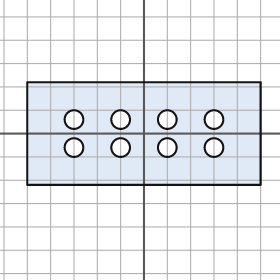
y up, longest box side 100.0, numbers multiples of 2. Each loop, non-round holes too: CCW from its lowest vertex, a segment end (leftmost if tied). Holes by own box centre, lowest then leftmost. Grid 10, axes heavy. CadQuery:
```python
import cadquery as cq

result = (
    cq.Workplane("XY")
    .moveTo(-50.0, -22.0)
    .lineTo(50.0, -22.0)
    .lineTo(50.0, 22.0)
    .lineTo(-50.0, 22.0)
    .close()
    .moveTo(-30.0, -6.0)
    .circle(4.0)
    .moveTo(-10.0, -6.0)
    .circle(4.0)
    .moveTo(10.0, -6.0)
    .circle(4.0)
    .moveTo(30.0, -6.0)
    .circle(4.0)
    .moveTo(-30.0, 6.0)
    .circle(4.0)
    .moveTo(-10.0, 6.0)
    .circle(4.0)
    .moveTo(10.0, 6.0)
    .circle(4.0)
    .moveTo(30.0, 6.0)
    .circle(4.0)
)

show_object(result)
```